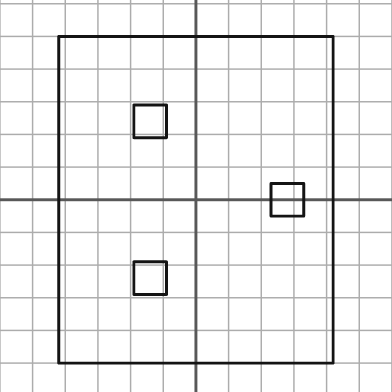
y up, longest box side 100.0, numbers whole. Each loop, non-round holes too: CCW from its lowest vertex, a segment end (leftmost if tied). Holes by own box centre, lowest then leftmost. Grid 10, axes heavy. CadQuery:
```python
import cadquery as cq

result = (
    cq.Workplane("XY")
    .moveTo(-42.0, -50.0)
    .lineTo(42.0, -50.0)
    .lineTo(42.0, 50.0)
    .lineTo(-42.0, 50.0)
    .close()
    .moveTo(-19.0, -29.0)
    .lineTo(-9.0, -29.0)
    .lineTo(-9.0, -19.0)
    .lineTo(-19.0, -19.0)
    .close()
    .moveTo(23.0, -5.0)
    .lineTo(33.0, -5.0)
    .lineTo(33.0, 5.0)
    .lineTo(23.0, 5.0)
    .close()
    .moveTo(-19.0, 19.0)
    .lineTo(-9.0, 19.0)
    .lineTo(-9.0, 29.0)
    .lineTo(-19.0, 29.0)
    .close()
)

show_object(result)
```